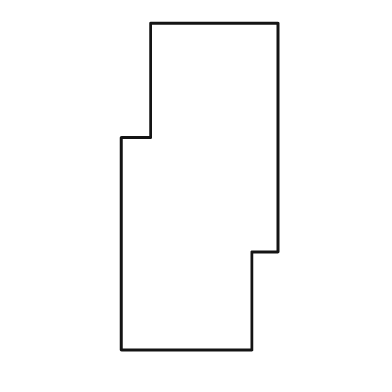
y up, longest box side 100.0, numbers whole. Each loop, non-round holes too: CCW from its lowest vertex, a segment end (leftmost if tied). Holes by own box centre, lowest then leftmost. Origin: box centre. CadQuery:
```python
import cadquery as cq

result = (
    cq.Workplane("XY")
    .moveTo(-24.0, -50.0)
    .lineTo(16.0, -50.0)
    .lineTo(16.0, -20.0)
    .lineTo(24.0, -20.0)
    .lineTo(24.0, 50.0)
    .lineTo(-15.0, 50.0)
    .lineTo(-15.0, 15.0)
    .lineTo(-24.0, 15.0)
    .close()
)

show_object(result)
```